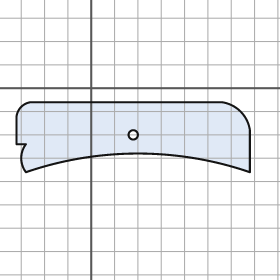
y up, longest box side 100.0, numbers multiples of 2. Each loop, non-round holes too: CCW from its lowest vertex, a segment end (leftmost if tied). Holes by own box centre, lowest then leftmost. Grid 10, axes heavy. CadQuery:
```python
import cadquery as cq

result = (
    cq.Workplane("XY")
    .moveTo(-28.0, -36.0)
    .threePointArc((20.0, -28.0), (68.0, -36.0))
    .lineTo(68.0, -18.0)
    .threePointArc((64.0, -10.0), (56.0, -6.0))
    .lineTo(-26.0, -6.0)
    .threePointArc((-30.0, -8.0), (-32.0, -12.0))
    .lineTo(-32.0, -24.0)
    .lineTo(-28.0, -24.0)
    .threePointArc((-30.0, -30.0), (-28.0, -36.0))
    .close()
    .moveTo(18.0, -20.0)
    .circle(2.0)
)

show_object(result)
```